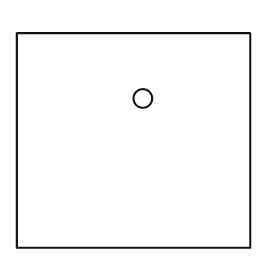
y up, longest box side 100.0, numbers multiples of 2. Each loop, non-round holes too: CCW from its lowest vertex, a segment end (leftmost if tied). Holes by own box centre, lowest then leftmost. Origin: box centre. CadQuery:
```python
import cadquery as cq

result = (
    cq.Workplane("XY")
    .moveTo(-50.0, -46.0)
    .lineTo(50.0, -46.0)
    .lineTo(50.0, 46.0)
    .lineTo(-50.0, 46.0)
    .close()
    .moveTo(4.0, 18.0)
    .circle(4.0)
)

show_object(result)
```